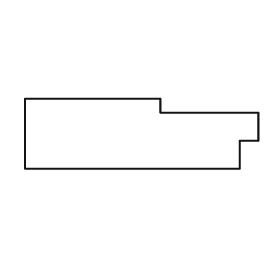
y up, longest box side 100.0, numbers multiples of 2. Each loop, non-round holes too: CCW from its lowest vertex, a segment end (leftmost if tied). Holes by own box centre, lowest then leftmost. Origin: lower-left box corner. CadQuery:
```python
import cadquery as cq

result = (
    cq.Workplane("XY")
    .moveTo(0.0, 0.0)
    .lineTo(92.0, 0.0)
    .lineTo(92.0, 12.0)
    .lineTo(100.0, 12.0)
    .lineTo(100.0, 24.0)
    .lineTo(58.0, 24.0)
    .lineTo(58.0, 30.0)
    .lineTo(0.0, 30.0)
    .close()
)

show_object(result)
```